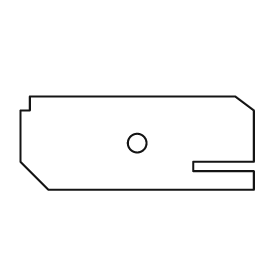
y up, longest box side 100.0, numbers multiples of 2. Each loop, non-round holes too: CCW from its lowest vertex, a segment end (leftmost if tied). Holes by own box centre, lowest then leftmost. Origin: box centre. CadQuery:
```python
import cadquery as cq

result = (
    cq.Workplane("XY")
    .moveTo(-38.0, -20.0)
    .lineTo(50.0, -20.0)
    .lineTo(50.0, -12.0)
    .lineTo(24.0, -12.0)
    .lineTo(24.0, -8.0)
    .lineTo(50.0, -8.0)
    .lineTo(50.0, 14.0)
    .lineTo(42.0, 20.0)
    .lineTo(-46.0, 20.0)
    .lineTo(-46.0, 14.0)
    .lineTo(-50.0, 14.0)
    .lineTo(-50.0, -8.0)
    .close()
    .moveTo(0.0, 0.0)
    .circle(4.0)
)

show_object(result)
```